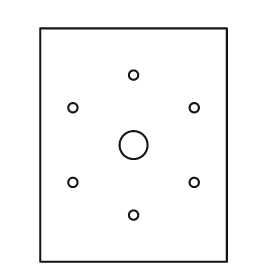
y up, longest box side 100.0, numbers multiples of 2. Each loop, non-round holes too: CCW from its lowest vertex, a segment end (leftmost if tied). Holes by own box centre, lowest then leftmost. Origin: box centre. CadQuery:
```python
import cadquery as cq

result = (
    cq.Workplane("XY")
    .moveTo(-40.0, -50.0)
    .lineTo(40.0, -50.0)
    .lineTo(40.0, 50.0)
    .lineTo(-40.0, 50.0)
    .close()
    .moveTo(0.0, -30.0)
    .circle(2.0)
    .moveTo(-26.0, -16.0)
    .circle(2.0)
    .moveTo(26.0, -16.0)
    .circle(2.0)
    .moveTo(0.0, 0.0)
    .circle(6.0)
    .moveTo(-26.0, 16.0)
    .circle(2.0)
    .moveTo(26.0, 16.0)
    .circle(2.0)
    .moveTo(0.0, 30.0)
    .circle(2.0)
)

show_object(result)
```